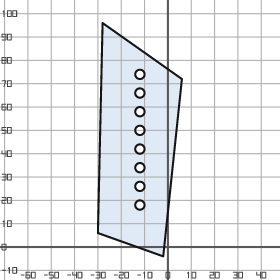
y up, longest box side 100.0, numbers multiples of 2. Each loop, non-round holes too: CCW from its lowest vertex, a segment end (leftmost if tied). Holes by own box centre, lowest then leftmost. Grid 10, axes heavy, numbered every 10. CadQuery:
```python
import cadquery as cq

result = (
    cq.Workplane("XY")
    .moveTo(-2.0, -4.0)
    .lineTo(6.0, 72.0)
    .lineTo(-28.0, 96.0)
    .lineTo(-30.0, 6.0)
    .close()
    .moveTo(-12.0, 18.0)
    .circle(2.0)
    .moveTo(-12.0, 26.0)
    .circle(2.0)
    .moveTo(-12.0, 34.0)
    .circle(2.0)
    .moveTo(-12.0, 42.0)
    .circle(2.0)
    .moveTo(-12.0, 50.0)
    .circle(2.0)
    .moveTo(-12.0, 58.0)
    .circle(2.0)
    .moveTo(-12.0, 66.0)
    .circle(2.0)
    .moveTo(-12.0, 74.0)
    .circle(2.0)
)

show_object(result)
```